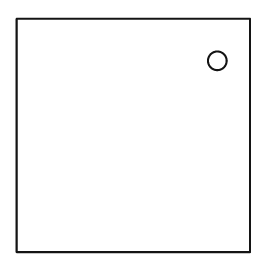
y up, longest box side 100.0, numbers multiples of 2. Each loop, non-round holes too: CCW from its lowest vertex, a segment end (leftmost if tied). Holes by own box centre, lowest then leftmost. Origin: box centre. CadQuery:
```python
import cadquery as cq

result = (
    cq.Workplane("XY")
    .moveTo(-50.0, -50.0)
    .lineTo(50.0, -50.0)
    .lineTo(50.0, 50.0)
    .lineTo(-50.0, 50.0)
    .close()
    .moveTo(36.0, 32.0)
    .circle(4.0)
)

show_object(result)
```